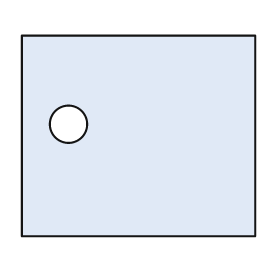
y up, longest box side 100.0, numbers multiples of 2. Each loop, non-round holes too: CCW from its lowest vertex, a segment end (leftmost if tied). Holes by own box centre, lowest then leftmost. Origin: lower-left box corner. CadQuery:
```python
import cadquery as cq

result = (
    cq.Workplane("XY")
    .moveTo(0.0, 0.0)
    .lineTo(100.0, 0.0)
    .lineTo(100.0, 86.0)
    .lineTo(0.0, 86.0)
    .close()
    .moveTo(20.0, 48.0)
    .circle(8.0)
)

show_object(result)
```